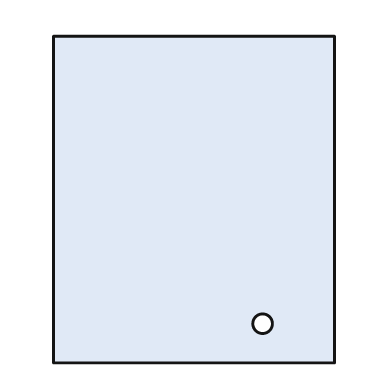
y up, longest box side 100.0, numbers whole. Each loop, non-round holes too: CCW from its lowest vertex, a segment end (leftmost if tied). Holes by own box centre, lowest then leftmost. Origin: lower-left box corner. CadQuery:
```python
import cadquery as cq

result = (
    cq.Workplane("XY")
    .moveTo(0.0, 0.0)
    .lineTo(86.0, 0.0)
    .lineTo(86.0, 100.0)
    .lineTo(0.0, 100.0)
    .close()
    .moveTo(64.0, 12.0)
    .circle(3.0)
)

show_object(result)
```